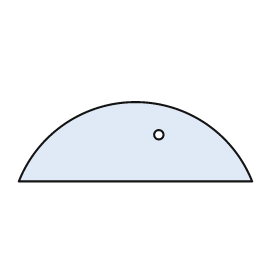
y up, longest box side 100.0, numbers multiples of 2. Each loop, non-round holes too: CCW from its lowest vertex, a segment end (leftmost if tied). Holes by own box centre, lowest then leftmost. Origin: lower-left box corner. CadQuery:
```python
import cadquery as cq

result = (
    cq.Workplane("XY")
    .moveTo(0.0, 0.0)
    .lineTo(100.0, 0.0)
    .threePointArc((50.0, 34.0), (0.0, 0.0))
    .close()
    .moveTo(60.0, 20.0)
    .circle(2.0)
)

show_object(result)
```